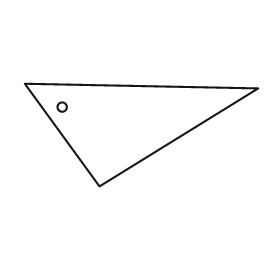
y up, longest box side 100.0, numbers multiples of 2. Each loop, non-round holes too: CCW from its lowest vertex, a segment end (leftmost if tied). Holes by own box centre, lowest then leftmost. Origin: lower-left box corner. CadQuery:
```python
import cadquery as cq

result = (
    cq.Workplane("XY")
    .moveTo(32.0, 0.0)
    .lineTo(100.0, 42.0)
    .lineTo(0.0, 44.0)
    .close()
    .moveTo(16.0, 34.0)
    .circle(2.0)
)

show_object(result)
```